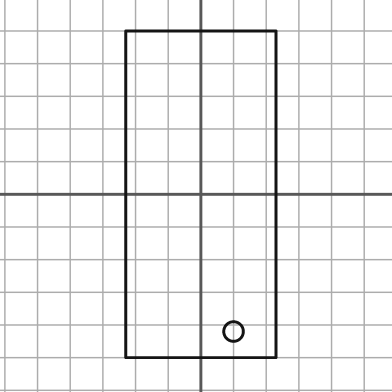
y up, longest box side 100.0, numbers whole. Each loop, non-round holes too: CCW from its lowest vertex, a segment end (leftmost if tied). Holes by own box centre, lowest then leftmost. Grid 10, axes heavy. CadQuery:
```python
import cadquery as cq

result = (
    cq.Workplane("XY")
    .moveTo(-23.0, -50.0)
    .lineTo(23.0, -50.0)
    .lineTo(23.0, 50.0)
    .lineTo(-23.0, 50.0)
    .close()
    .moveTo(10.0, -42.0)
    .circle(3.0)
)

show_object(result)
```